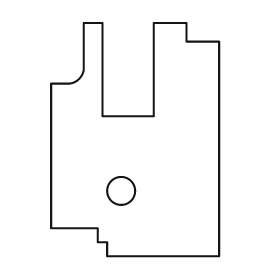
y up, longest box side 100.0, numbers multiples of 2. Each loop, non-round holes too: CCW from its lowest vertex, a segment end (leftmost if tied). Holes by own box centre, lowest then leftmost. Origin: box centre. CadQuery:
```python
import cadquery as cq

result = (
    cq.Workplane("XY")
    .moveTo(-12.0, -50.0)
    .lineTo(36.0, -50.0)
    .lineTo(36.0, 42.0)
    .lineTo(22.0, 42.0)
    .lineTo(22.0, 50.0)
    .lineTo(8.0, 50.0)
    .lineTo(8.0, 10.0)
    .lineTo(-14.0, 10.0)
    .lineTo(-14.0, 50.0)
    .lineTo(-22.0, 50.0)
    .lineTo(-22.0, 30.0)
    .threePointArc((-24.0, 26.0), (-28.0, 24.0))
    .lineTo(-36.0, 24.0)
    .lineTo(-36.0, -38.0)
    .lineTo(-16.0, -38.0)
    .lineTo(-16.0, -44.0)
    .lineTo(-12.0, -44.0)
    .close()
    .moveTo(-6.0, -22.0)
    .circle(6.0)
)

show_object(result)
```